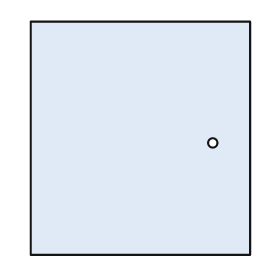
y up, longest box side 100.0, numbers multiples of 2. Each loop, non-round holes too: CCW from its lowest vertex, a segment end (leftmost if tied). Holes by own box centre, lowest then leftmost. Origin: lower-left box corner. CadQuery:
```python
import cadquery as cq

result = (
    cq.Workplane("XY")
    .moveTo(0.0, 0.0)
    .lineTo(94.0, 0.0)
    .lineTo(94.0, 100.0)
    .lineTo(0.0, 100.0)
    .close()
    .moveTo(78.0, 48.0)
    .circle(2.0)
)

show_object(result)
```